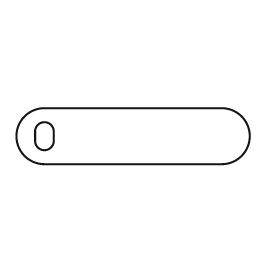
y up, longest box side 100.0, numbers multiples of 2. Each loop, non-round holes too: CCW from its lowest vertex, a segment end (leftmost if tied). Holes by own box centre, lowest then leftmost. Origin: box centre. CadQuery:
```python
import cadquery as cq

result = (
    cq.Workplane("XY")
    .moveTo(-38.0, -12.0)
    .lineTo(38.0, -12.0)
    .threePointArc((50.0, 0.0), (38.0, 12.0))
    .lineTo(-38.0, 12.0)
    .threePointArc((-50.0, 0.0), (-38.0, -12.0))
    .close()
    .moveTo(-42.0, -2.0)
    .threePointArc((-38.0, -6.0), (-34.0, -2.0))
    .lineTo(-34.0, 2.0)
    .threePointArc((-38.0, 6.0), (-42.0, 2.0))
    .close()
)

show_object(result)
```